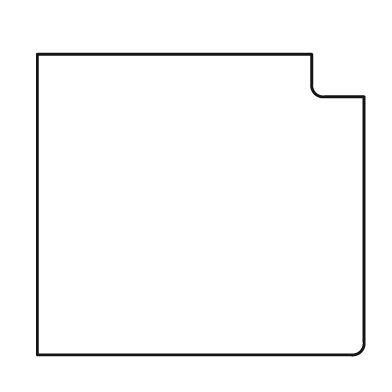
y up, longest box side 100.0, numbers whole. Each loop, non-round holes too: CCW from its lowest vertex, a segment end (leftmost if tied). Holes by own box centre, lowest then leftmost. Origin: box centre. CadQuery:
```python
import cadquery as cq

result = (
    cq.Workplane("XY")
    .moveTo(-50.0, -46.0)
    .lineTo(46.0, -46.0)
    .threePointArc((49.0, -45.0), (50.0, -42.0))
    .lineTo(50.0, 33.0)
    .lineTo(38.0, 33.0)
    .threePointArc((35.0, 34.0), (34.0, 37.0))
    .lineTo(34.0, 46.0)
    .lineTo(-50.0, 46.0)
    .close()
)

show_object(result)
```